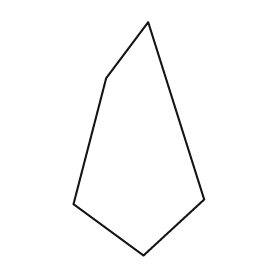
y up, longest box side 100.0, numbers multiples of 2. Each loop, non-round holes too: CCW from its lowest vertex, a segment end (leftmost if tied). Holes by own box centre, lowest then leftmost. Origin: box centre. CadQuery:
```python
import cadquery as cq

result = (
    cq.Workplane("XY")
    .moveTo(2.0, -50.0)
    .lineTo(28.0, -26.0)
    .lineTo(4.0, 50.0)
    .lineTo(-14.0, 26.0)
    .lineTo(-28.0, -28.0)
    .close()
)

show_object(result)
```